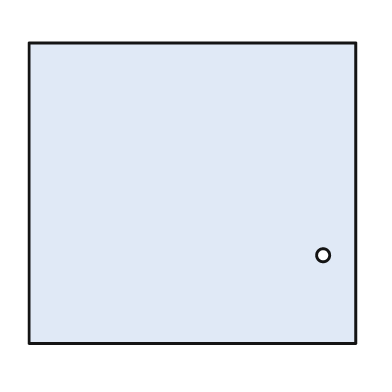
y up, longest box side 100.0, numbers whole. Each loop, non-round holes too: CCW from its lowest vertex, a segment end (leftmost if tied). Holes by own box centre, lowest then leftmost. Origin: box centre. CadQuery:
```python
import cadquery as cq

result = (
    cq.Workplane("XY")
    .moveTo(-50.0, -46.0)
    .lineTo(50.0, -46.0)
    .lineTo(50.0, 46.0)
    .lineTo(-50.0, 46.0)
    .close()
    .moveTo(40.0, -19.0)
    .circle(2.0)
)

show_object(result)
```